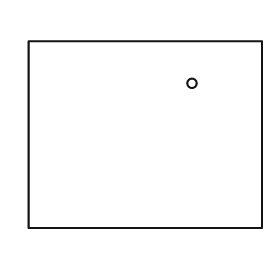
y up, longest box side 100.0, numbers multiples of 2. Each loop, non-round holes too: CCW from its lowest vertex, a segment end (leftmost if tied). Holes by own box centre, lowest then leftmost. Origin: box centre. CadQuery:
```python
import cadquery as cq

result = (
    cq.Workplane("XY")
    .moveTo(-50.0, -40.0)
    .lineTo(50.0, -40.0)
    .lineTo(50.0, 40.0)
    .lineTo(-50.0, 40.0)
    .close()
    .moveTo(20.0, 22.0)
    .circle(2.0)
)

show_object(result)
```